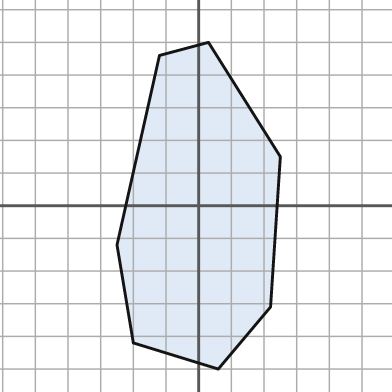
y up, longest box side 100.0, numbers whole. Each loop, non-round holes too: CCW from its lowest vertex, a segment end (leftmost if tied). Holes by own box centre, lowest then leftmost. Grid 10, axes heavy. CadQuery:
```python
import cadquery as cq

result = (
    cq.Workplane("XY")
    .moveTo(6.0, -50.0)
    .lineTo(22.0, -31.0)
    .lineTo(25.0, 15.0)
    .lineTo(3.0, 50.0)
    .lineTo(-12.0, 46.0)
    .lineTo(-25.0, -12.0)
    .lineTo(-20.0, -42.0)
    .close()
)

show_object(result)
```